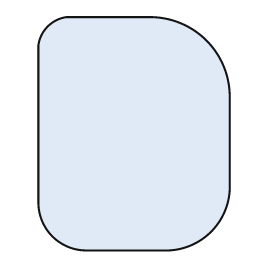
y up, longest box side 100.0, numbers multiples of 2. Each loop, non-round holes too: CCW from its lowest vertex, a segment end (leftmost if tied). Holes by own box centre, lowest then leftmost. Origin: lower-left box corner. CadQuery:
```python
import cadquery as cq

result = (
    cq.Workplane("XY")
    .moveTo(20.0, 0.0)
    .lineTo(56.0, 0.0)
    .threePointArc((74.0, 8.0), (82.0, 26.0))
    .lineTo(82.0, 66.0)
    .threePointArc((72.0, 90.0), (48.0, 100.0))
    .lineTo(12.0, 100.0)
    .threePointArc((4.0, 96.0), (0.0, 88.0))
    .lineTo(0.0, 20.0)
    .threePointArc((6.0, 6.0), (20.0, 0.0))
    .close()
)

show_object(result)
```